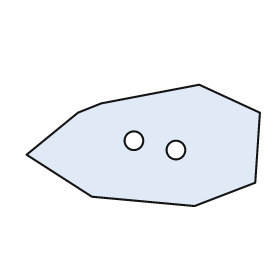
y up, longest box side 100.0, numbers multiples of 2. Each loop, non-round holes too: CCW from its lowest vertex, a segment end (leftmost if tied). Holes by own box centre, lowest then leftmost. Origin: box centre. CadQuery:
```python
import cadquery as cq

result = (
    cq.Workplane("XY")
    .moveTo(22.0, -26.0)
    .lineTo(48.0, -16.0)
    .lineTo(50.0, 14.0)
    .lineTo(24.0, 26.0)
    .lineTo(-18.0, 18.0)
    .lineTo(-28.0, 14.0)
    .lineTo(-50.0, -4.0)
    .lineTo(-22.0, -22.0)
    .close()
    .moveTo(14.0, -2.0)
    .circle(4.0)
    .moveTo(-4.0, 2.0)
    .circle(4.0)
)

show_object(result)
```